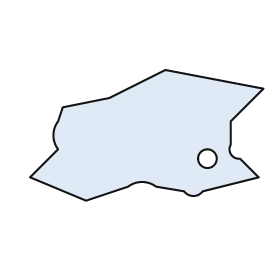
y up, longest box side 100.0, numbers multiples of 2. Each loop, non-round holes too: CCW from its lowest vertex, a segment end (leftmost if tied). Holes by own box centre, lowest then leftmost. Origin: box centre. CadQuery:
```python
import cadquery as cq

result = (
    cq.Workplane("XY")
    .moveTo(-26.0, -28.0)
    .lineTo(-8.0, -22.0)
    .threePointArc((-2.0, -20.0), (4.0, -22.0))
    .lineTo(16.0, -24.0)
    .threePointArc((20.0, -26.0), (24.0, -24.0))
    .lineTo(48.0, -18.0)
    .lineTo(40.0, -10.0)
    .threePointArc((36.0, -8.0), (36.0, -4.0))
    .lineTo(36.0, 6.0)
    .lineTo(50.0, 20.0)
    .lineTo(8.0, 28.0)
    .lineTo(-16.0, 16.0)
    .lineTo(-36.0, 12.0)
    .lineTo(-38.0, 6.0)
    .threePointArc((-40.0, 0.0), (-38.0, -6.0))
    .lineTo(-50.0, -18.0)
    .close()
    .moveTo(26.0, -10.0)
    .circle(4.0)
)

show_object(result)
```